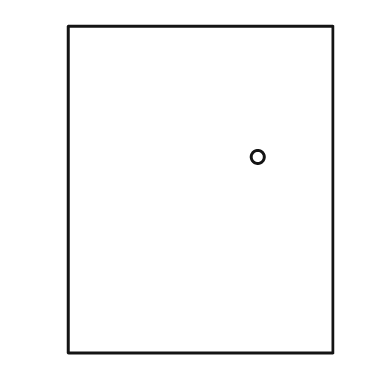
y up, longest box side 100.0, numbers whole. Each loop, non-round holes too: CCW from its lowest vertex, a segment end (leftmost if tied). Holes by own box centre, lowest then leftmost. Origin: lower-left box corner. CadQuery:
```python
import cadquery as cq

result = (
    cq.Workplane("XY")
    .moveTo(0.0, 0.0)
    .lineTo(81.0, 0.0)
    .lineTo(81.0, 100.0)
    .lineTo(0.0, 100.0)
    .close()
    .moveTo(58.0, 60.0)
    .circle(2.0)
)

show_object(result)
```